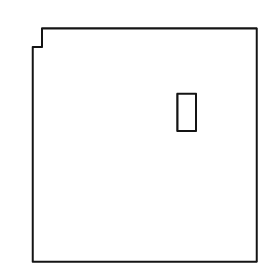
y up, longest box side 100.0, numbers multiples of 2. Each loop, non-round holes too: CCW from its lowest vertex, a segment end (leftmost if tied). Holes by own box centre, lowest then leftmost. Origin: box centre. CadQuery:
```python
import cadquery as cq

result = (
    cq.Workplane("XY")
    .moveTo(-48.0, -50.0)
    .lineTo(48.0, -50.0)
    .lineTo(48.0, 50.0)
    .lineTo(-44.0, 50.0)
    .lineTo(-44.0, 42.0)
    .lineTo(-48.0, 42.0)
    .close()
    .moveTo(14.0, 6.0)
    .lineTo(22.0, 6.0)
    .lineTo(22.0, 22.0)
    .lineTo(14.0, 22.0)
    .close()
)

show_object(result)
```